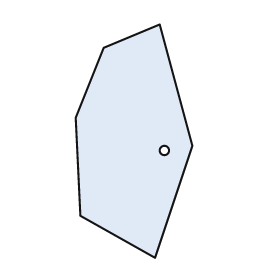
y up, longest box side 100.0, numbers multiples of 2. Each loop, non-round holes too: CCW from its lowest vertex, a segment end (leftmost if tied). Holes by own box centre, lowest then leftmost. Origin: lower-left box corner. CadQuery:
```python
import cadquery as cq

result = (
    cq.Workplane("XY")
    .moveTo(34.0, 0.0)
    .lineTo(50.0, 48.0)
    .lineTo(36.0, 100.0)
    .lineTo(12.0, 90.0)
    .lineTo(0.0, 60.0)
    .lineTo(2.0, 18.0)
    .close()
    .moveTo(38.0, 46.0)
    .circle(2.0)
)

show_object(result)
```